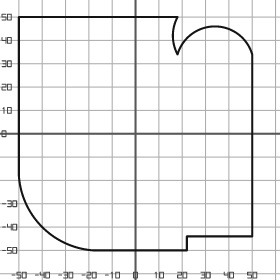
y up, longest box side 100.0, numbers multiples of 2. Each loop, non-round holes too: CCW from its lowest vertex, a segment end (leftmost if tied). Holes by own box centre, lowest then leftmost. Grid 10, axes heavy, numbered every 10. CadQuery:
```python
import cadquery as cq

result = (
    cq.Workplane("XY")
    .moveTo(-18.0, -50.0)
    .lineTo(22.0, -50.0)
    .lineTo(22.0, -44.0)
    .lineTo(50.0, -44.0)
    .lineTo(50.0, 34.0)
    .threePointArc((34.0, 46.0), (18.0, 34.0))
    .threePointArc((16.0, 42.0), (18.0, 50.0))
    .lineTo(-50.0, 50.0)
    .lineTo(-50.0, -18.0)
    .threePointArc((-40.0, -40.0), (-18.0, -50.0))
    .close()
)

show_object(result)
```